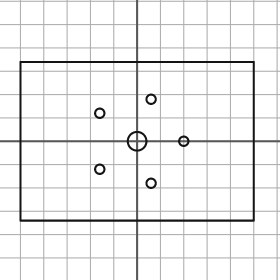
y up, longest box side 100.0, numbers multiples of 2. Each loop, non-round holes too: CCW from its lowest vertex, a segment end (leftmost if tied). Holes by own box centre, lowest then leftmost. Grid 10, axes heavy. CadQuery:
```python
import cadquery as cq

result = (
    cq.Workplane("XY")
    .moveTo(-50.0, -34.0)
    .lineTo(50.0, -34.0)
    .lineTo(50.0, 34.0)
    .lineTo(-50.0, 34.0)
    .close()
    .moveTo(6.0, -18.0)
    .circle(2.0)
    .moveTo(-16.0, -12.0)
    .circle(2.0)
    .moveTo(0.0, 0.0)
    .circle(4.0)
    .moveTo(20.0, 0.0)
    .circle(2.0)
    .moveTo(-16.0, 12.0)
    .circle(2.0)
    .moveTo(6.0, 18.0)
    .circle(2.0)
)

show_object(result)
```